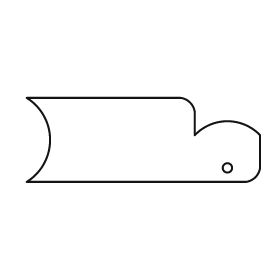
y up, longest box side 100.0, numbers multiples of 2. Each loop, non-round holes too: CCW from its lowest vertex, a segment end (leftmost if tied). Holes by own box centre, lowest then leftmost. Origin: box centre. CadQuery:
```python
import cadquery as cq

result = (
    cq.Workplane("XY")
    .moveTo(-50.0, -18.0)
    .lineTo(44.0, -18.0)
    .threePointArc((48.0, -16.0), (50.0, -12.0))
    .lineTo(50.0, 2.0)
    .threePointArc((36.0, 8.0), (22.0, 2.0))
    .lineTo(22.0, 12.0)
    .threePointArc((20.0, 16.0), (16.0, 18.0))
    .lineTo(-50.0, 18.0)
    .threePointArc((-40.0, 0.0), (-50.0, -18.0))
    .close()
    .moveTo(36.0, -12.0)
    .circle(2.0)
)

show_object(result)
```